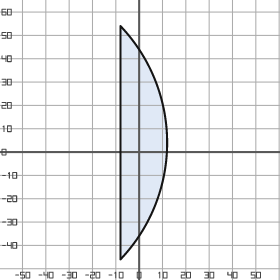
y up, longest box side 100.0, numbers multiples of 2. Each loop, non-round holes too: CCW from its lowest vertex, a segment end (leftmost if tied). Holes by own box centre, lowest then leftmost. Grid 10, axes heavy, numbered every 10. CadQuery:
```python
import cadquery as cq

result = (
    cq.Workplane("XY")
    .moveTo(-8.0, -46.0)
    .threePointArc((12.0, 4.0), (-8.0, 54.0))
    .close()
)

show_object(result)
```